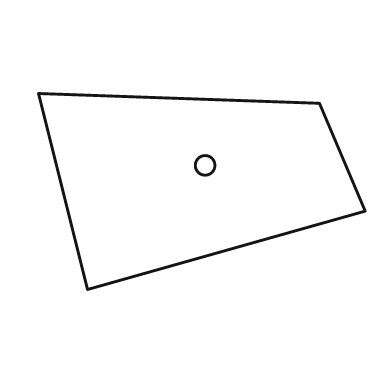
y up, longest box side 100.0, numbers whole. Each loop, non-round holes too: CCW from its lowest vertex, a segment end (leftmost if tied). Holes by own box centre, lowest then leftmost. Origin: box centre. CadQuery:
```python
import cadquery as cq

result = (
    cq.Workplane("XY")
    .moveTo(-35.0, -30.0)
    .lineTo(50.0, -6.0)
    .lineTo(36.0, 27.0)
    .lineTo(-50.0, 30.0)
    .close()
    .moveTo(1.0, 8.0)
    .circle(3.0)
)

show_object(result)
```